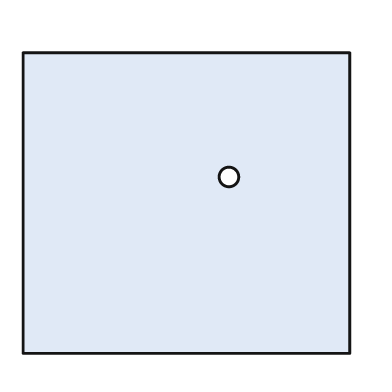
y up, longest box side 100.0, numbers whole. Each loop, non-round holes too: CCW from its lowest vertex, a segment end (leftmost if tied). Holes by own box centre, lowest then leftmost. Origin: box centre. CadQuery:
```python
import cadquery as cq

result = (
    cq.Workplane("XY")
    .moveTo(-50.0, -46.0)
    .lineTo(50.0, -46.0)
    .lineTo(50.0, 46.0)
    .lineTo(-50.0, 46.0)
    .close()
    .moveTo(13.0, 8.0)
    .circle(3.0)
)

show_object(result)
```